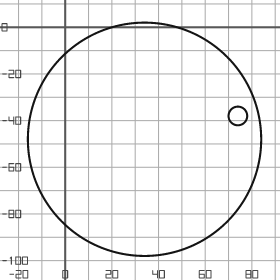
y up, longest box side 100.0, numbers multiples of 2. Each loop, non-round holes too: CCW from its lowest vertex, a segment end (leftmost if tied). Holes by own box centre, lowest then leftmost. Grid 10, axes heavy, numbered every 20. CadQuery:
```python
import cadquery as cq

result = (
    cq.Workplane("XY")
    .moveTo(34.0, -48.0)
    .circle(50.0)
    .moveTo(74.0, -38.0)
    .circle(4.0)
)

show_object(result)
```